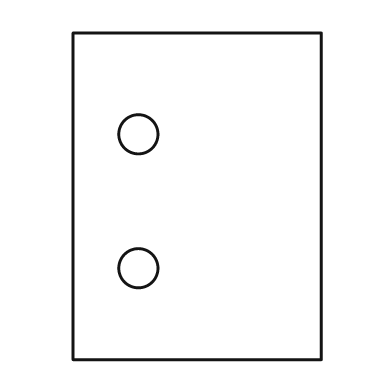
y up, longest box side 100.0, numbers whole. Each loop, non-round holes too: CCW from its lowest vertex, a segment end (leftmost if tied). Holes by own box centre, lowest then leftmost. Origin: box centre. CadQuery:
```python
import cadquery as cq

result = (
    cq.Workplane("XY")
    .moveTo(-38.0, -50.0)
    .lineTo(38.0, -50.0)
    .lineTo(38.0, 50.0)
    .lineTo(-38.0, 50.0)
    .close()
    .moveTo(-18.0, -22.0)
    .circle(6.0)
    .moveTo(-18.0, 19.0)
    .circle(6.0)
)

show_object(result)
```